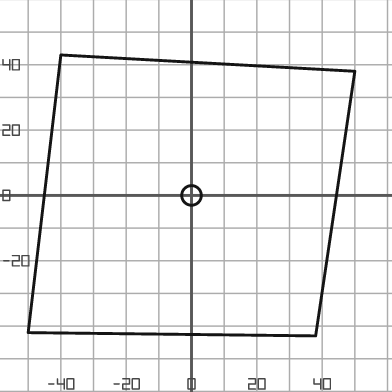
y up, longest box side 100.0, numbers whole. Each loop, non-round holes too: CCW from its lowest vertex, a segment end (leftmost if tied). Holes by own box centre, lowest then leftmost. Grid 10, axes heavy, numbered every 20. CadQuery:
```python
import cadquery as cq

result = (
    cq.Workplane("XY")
    .moveTo(38.0, -43.0)
    .lineTo(50.0, 38.0)
    .lineTo(-40.0, 43.0)
    .lineTo(-50.0, -42.0)
    .close()
    .moveTo(0.0, 0.0)
    .circle(3.0)
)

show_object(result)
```